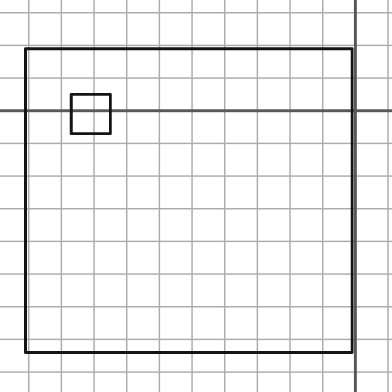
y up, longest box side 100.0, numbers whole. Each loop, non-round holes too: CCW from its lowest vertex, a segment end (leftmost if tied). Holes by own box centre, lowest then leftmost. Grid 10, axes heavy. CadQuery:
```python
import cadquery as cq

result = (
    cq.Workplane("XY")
    .moveTo(-101.0, -74.0)
    .lineTo(-1.0, -74.0)
    .lineTo(-1.0, 19.0)
    .lineTo(-101.0, 19.0)
    .close()
    .moveTo(-87.0, -7.0)
    .lineTo(-75.0, -7.0)
    .lineTo(-75.0, 5.0)
    .lineTo(-87.0, 5.0)
    .close()
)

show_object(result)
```